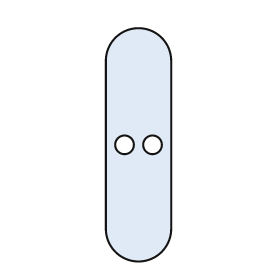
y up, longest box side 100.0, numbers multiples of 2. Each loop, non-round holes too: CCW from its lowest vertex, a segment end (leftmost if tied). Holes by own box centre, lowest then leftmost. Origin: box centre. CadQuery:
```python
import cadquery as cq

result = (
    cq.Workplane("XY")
    .moveTo(-14.0, -36.0)
    .threePointArc((0.0, -50.0), (14.0, -36.0))
    .lineTo(14.0, 36.0)
    .threePointArc((0.0, 50.0), (-14.0, 36.0))
    .close()
    .moveTo(-6.0, 0.0)
    .circle(4.0)
    .moveTo(6.0, 0.0)
    .circle(4.0)
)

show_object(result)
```